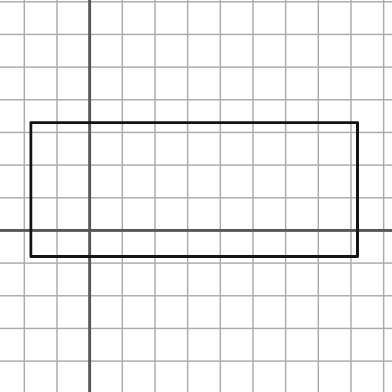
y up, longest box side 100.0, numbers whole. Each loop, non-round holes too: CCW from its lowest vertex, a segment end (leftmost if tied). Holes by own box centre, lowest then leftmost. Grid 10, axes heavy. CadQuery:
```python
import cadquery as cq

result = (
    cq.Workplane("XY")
    .moveTo(-18.0, -8.0)
    .lineTo(82.0, -8.0)
    .lineTo(82.0, 33.0)
    .lineTo(-18.0, 33.0)
    .close()
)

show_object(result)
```